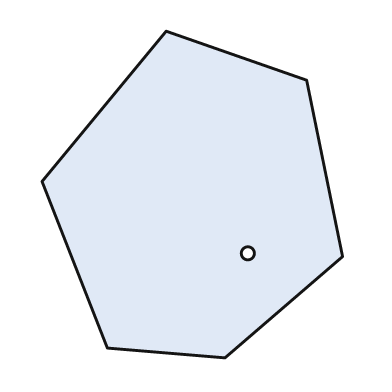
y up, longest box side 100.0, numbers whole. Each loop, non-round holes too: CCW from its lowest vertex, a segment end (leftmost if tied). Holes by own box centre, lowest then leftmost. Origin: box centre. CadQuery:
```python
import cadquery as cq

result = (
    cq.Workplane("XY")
    .moveTo(10.0, -50.0)
    .lineTo(46.0, -19.0)
    .lineTo(35.0, 35.0)
    .lineTo(-8.0, 50.0)
    .lineTo(-46.0, 4.0)
    .lineTo(-26.0, -47.0)
    .close()
    .moveTo(17.0, -18.0)
    .circle(2.0)
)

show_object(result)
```